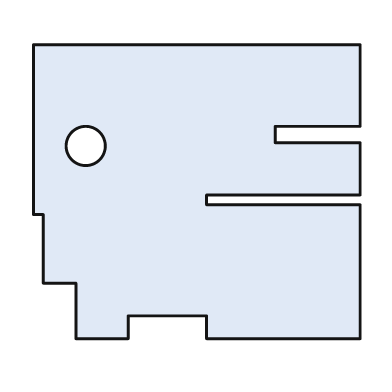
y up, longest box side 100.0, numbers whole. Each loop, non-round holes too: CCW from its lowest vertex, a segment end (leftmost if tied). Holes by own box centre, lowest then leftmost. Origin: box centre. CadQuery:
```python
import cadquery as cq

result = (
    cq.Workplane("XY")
    .moveTo(-37.0, -45.0)
    .lineTo(-21.0, -45.0)
    .lineTo(-21.0, -38.0)
    .lineTo(3.0, -38.0)
    .lineTo(3.0, -45.0)
    .lineTo(50.0, -45.0)
    .lineTo(50.0, -4.0)
    .lineTo(3.0, -4.0)
    .lineTo(3.0, -1.0)
    .lineTo(50.0, -1.0)
    .lineTo(50.0, 15.0)
    .lineTo(24.0, 15.0)
    .lineTo(24.0, 20.0)
    .lineTo(50.0, 20.0)
    .lineTo(50.0, 45.0)
    .lineTo(-50.0, 45.0)
    .lineTo(-50.0, -7.0)
    .lineTo(-47.0, -7.0)
    .lineTo(-47.0, -28.0)
    .lineTo(-37.0, -28.0)
    .close()
    .moveTo(-34.0, 14.0)
    .circle(6.0)
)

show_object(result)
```